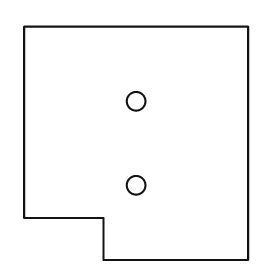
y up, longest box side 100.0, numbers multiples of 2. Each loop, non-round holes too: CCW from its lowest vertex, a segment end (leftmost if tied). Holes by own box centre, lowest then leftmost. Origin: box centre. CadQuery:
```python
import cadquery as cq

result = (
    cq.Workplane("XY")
    .moveTo(-14.0, -50.0)
    .lineTo(48.0, -50.0)
    .lineTo(48.0, 50.0)
    .lineTo(-48.0, 50.0)
    .lineTo(-48.0, -32.0)
    .lineTo(-14.0, -32.0)
    .close()
    .moveTo(0.0, -18.0)
    .circle(4.0)
    .moveTo(0.0, 18.0)
    .circle(4.0)
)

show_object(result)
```